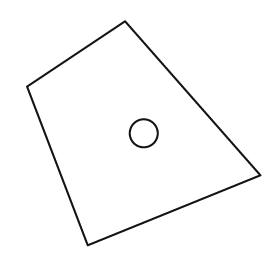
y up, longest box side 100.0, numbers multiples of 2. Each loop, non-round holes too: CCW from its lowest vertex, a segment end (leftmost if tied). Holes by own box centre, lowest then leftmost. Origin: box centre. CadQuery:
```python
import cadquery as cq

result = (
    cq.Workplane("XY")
    .moveTo(-24.0, -48.0)
    .lineTo(50.0, -18.0)
    .lineTo(-8.0, 48.0)
    .lineTo(-50.0, 20.0)
    .close()
    .moveTo(0.0, 0.0)
    .circle(6.0)
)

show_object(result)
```